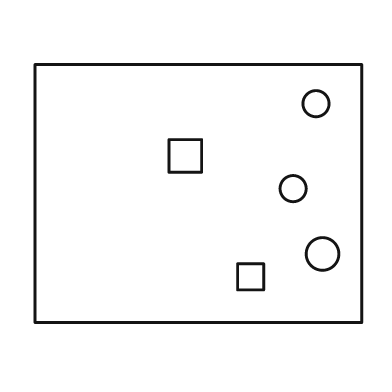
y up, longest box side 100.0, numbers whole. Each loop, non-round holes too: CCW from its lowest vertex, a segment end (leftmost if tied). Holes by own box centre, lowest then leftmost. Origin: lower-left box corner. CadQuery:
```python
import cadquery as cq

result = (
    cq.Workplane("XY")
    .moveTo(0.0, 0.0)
    .lineTo(100.0, 0.0)
    .lineTo(100.0, 79.0)
    .lineTo(0.0, 79.0)
    .close()
    .moveTo(62.0, 10.0)
    .lineTo(70.0, 10.0)
    .lineTo(70.0, 18.0)
    .lineTo(62.0, 18.0)
    .close()
    .moveTo(88.0, 21.0)
    .circle(5.0)
    .moveTo(79.0, 41.0)
    .circle(4.0)
    .moveTo(41.0, 46.0)
    .lineTo(51.0, 46.0)
    .lineTo(51.0, 56.0)
    .lineTo(41.0, 56.0)
    .close()
    .moveTo(86.0, 67.0)
    .circle(4.0)
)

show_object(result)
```